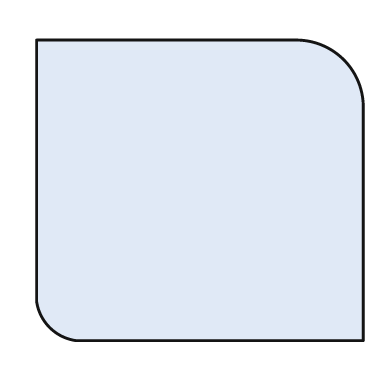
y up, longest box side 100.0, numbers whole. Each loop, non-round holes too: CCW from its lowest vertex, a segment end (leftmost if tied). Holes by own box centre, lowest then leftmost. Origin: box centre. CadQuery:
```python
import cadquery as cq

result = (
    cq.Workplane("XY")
    .moveTo(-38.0, -46.0)
    .lineTo(50.0, -46.0)
    .lineTo(50.0, 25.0)
    .threePointArc((44.0, 40.0), (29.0, 46.0))
    .lineTo(-50.0, 46.0)
    .lineTo(-50.0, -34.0)
    .threePointArc((-46.0, -42.0), (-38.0, -46.0))
    .close()
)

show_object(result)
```